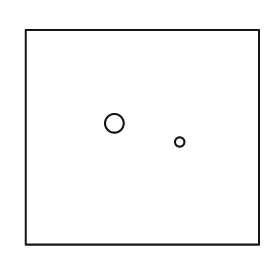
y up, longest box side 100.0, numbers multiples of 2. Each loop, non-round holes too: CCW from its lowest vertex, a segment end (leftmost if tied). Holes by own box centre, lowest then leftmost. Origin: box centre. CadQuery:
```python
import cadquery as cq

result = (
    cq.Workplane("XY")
    .moveTo(-50.0, -46.0)
    .lineTo(50.0, -46.0)
    .lineTo(50.0, 46.0)
    .lineTo(-50.0, 46.0)
    .close()
    .moveTo(16.0, -2.0)
    .circle(2.0)
    .moveTo(-12.0, 6.0)
    .circle(4.0)
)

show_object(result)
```